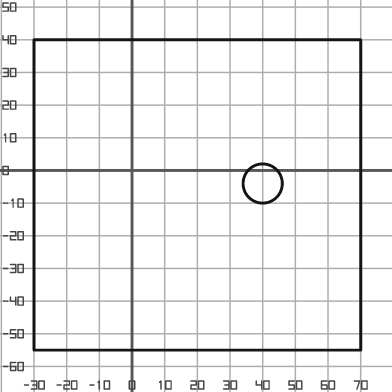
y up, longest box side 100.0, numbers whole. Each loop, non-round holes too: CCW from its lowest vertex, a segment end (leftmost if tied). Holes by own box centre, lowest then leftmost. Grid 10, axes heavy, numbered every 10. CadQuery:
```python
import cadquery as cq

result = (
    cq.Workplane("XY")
    .moveTo(-30.0, -55.0)
    .lineTo(70.0, -55.0)
    .lineTo(70.0, 40.0)
    .lineTo(-30.0, 40.0)
    .close()
    .moveTo(40.0, -4.0)
    .circle(6.0)
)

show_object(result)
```